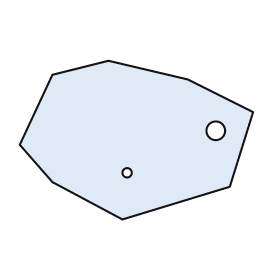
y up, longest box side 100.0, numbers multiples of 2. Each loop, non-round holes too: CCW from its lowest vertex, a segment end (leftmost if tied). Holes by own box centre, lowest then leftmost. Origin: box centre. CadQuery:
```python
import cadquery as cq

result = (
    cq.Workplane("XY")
    .moveTo(-6.0, -34.0)
    .lineTo(40.0, -20.0)
    .lineTo(50.0, 12.0)
    .lineTo(22.0, 26.0)
    .lineTo(-12.0, 34.0)
    .lineTo(-36.0, 28.0)
    .lineTo(-50.0, -2.0)
    .lineTo(-36.0, -18.0)
    .close()
    .moveTo(-4.0, -14.0)
    .circle(2.0)
    .moveTo(34.0, 4.0)
    .circle(4.0)
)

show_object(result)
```